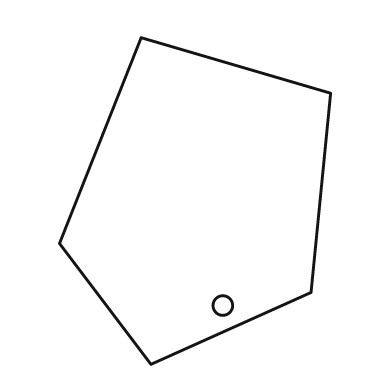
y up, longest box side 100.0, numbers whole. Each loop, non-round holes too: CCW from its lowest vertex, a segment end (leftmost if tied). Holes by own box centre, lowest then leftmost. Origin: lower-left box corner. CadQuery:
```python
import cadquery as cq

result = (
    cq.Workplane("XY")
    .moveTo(28.0, 0.0)
    .lineTo(77.0, 22.0)
    .lineTo(83.0, 83.0)
    .lineTo(25.0, 100.0)
    .lineTo(0.0, 37.0)
    .close()
    .moveTo(50.0, 18.0)
    .circle(3.0)
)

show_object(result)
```